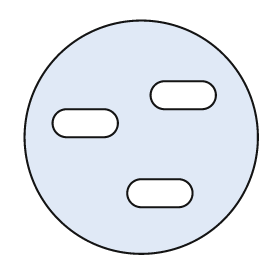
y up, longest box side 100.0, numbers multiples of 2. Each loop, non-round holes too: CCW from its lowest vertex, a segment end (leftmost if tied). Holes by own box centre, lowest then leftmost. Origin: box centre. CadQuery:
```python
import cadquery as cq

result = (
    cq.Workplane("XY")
    .moveTo(0.0, 0.0)
    .circle(50.0)
    .moveTo(0.0, -30.0)
    .lineTo(16.0, -30.0)
    .threePointArc((22.0, -24.0), (16.0, -18.0))
    .lineTo(0.0, -18.0)
    .threePointArc((-6.0, -24.0), (0.0, -30.0))
    .close()
    .moveTo(-32.0, 0.0)
    .lineTo(-16.0, 0.0)
    .threePointArc((-10.0, 6.0), (-16.0, 12.0))
    .lineTo(-32.0, 12.0)
    .threePointArc((-38.0, 6.0), (-32.0, 0.0))
    .close()
    .moveTo(10.0, 12.0)
    .lineTo(26.0, 12.0)
    .threePointArc((32.0, 18.0), (26.0, 24.0))
    .lineTo(10.0, 24.0)
    .threePointArc((4.0, 18.0), (10.0, 12.0))
    .close()
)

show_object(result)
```